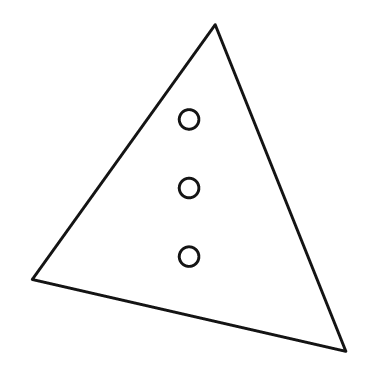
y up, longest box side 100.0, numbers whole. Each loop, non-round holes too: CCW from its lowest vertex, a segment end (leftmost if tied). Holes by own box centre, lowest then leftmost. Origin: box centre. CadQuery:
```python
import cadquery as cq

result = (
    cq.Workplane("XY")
    .moveTo(48.0, -50.0)
    .lineTo(8.0, 50.0)
    .lineTo(-48.0, -28.0)
    .close()
    .moveTo(0.0, -21.0)
    .circle(3.0)
    .moveTo(0.0, 0.0)
    .circle(3.0)
    .moveTo(0.0, 21.0)
    .circle(3.0)
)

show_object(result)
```